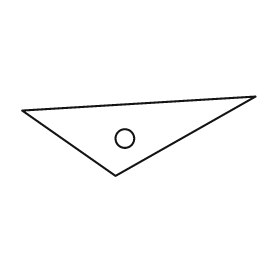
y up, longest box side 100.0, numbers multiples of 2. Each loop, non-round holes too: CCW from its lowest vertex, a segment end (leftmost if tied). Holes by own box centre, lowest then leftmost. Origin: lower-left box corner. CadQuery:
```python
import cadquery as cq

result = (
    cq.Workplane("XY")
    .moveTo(40.0, 0.0)
    .lineTo(100.0, 34.0)
    .lineTo(0.0, 28.0)
    .close()
    .moveTo(44.0, 16.0)
    .circle(4.0)
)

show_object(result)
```